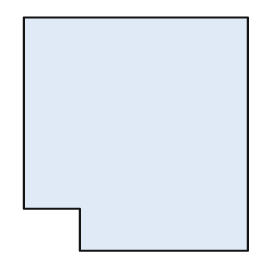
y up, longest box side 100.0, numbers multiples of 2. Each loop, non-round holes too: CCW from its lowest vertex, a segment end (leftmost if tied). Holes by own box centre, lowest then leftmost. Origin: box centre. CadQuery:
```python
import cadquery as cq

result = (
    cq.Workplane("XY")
    .moveTo(-24.0, -50.0)
    .lineTo(48.0, -50.0)
    .lineTo(48.0, 50.0)
    .lineTo(-48.0, 50.0)
    .lineTo(-48.0, -32.0)
    .lineTo(-24.0, -32.0)
    .close()
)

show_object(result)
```